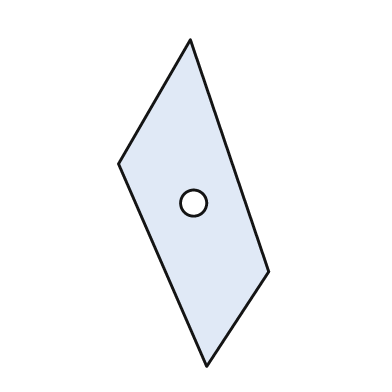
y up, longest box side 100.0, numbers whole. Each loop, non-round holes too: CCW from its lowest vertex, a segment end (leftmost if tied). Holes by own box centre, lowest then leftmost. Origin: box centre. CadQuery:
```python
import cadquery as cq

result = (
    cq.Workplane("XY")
    .moveTo(4.0, -50.0)
    .lineTo(23.0, -21.0)
    .lineTo(-1.0, 50.0)
    .lineTo(-23.0, 12.0)
    .close()
    .moveTo(0.0, 0.0)
    .circle(4.0)
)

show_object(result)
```